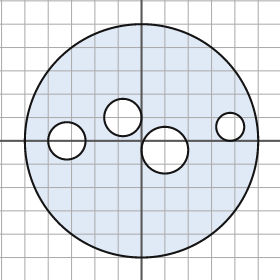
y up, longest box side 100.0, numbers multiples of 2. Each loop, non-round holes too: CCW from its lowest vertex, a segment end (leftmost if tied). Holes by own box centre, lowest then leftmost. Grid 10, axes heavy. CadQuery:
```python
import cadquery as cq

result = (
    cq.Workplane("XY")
    .moveTo(0.0, 0.0)
    .circle(50.0)
    .moveTo(10.0, -4.0)
    .circle(10.0)
    .moveTo(-32.0, 0.0)
    .circle(8.0)
    .moveTo(38.0, 6.0)
    .circle(6.0)
    .moveTo(-8.0, 10.0)
    .circle(8.0)
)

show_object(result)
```